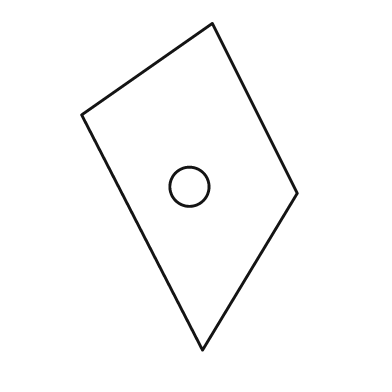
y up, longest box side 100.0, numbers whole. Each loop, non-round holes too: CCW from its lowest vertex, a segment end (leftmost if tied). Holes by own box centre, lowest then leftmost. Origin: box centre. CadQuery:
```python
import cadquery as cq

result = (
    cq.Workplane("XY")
    .moveTo(4.0, -50.0)
    .lineTo(33.0, -2.0)
    .lineTo(7.0, 50.0)
    .lineTo(-33.0, 22.0)
    .close()
    .moveTo(0.0, 0.0)
    .circle(6.0)
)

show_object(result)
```